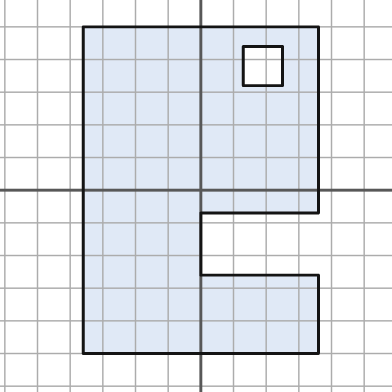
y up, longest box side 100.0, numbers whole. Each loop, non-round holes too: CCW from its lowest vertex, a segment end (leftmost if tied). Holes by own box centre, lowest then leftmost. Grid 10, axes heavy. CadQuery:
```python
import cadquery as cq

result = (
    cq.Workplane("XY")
    .moveTo(-36.0, -50.0)
    .lineTo(36.0, -50.0)
    .lineTo(36.0, -26.0)
    .lineTo(0.0, -26.0)
    .lineTo(0.0, -7.0)
    .lineTo(36.0, -7.0)
    .lineTo(36.0, 50.0)
    .lineTo(-36.0, 50.0)
    .close()
    .moveTo(13.0, 32.0)
    .lineTo(25.0, 32.0)
    .lineTo(25.0, 44.0)
    .lineTo(13.0, 44.0)
    .close()
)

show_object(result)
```